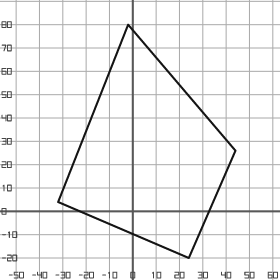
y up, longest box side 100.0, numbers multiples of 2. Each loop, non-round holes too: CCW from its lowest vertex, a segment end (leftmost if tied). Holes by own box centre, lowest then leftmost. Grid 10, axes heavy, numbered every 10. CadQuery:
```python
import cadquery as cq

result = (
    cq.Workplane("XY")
    .moveTo(24.0, -20.0)
    .lineTo(44.0, 26.0)
    .lineTo(-2.0, 80.0)
    .lineTo(-32.0, 4.0)
    .close()
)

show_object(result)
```